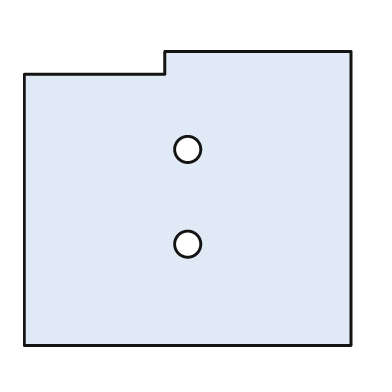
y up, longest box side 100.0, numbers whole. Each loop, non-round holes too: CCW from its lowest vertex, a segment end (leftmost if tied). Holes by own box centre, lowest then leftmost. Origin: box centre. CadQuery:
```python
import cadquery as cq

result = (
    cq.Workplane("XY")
    .moveTo(-50.0, -45.0)
    .lineTo(50.0, -45.0)
    .lineTo(50.0, 45.0)
    .lineTo(-7.0, 45.0)
    .lineTo(-7.0, 38.0)
    .lineTo(-50.0, 38.0)
    .close()
    .moveTo(0.0, -14.0)
    .circle(4.0)
    .moveTo(0.0, 15.0)
    .circle(4.0)
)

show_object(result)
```